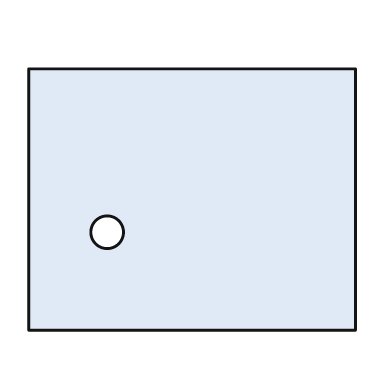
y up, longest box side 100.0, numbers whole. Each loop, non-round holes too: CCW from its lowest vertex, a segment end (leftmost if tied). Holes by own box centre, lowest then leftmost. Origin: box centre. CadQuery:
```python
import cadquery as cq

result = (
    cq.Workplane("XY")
    .moveTo(-50.0, -40.0)
    .lineTo(50.0, -40.0)
    .lineTo(50.0, 40.0)
    .lineTo(-50.0, 40.0)
    .close()
    .moveTo(-26.0, -10.0)
    .circle(5.0)
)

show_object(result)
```